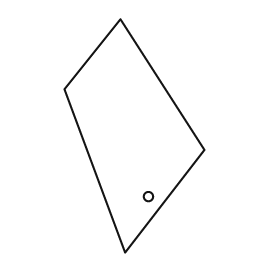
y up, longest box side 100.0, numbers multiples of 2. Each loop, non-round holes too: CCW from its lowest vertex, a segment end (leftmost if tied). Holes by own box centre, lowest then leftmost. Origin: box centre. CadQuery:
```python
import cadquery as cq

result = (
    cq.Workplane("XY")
    .moveTo(-4.0, -50.0)
    .lineTo(30.0, -6.0)
    .lineTo(-6.0, 50.0)
    .lineTo(-30.0, 20.0)
    .close()
    .moveTo(6.0, -26.0)
    .circle(2.0)
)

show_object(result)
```